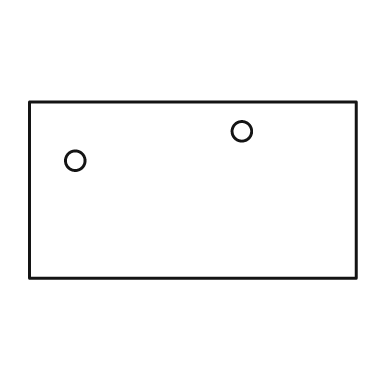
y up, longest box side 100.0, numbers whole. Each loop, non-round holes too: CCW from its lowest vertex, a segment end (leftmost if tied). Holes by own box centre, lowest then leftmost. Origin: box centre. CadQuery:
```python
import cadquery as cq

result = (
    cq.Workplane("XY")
    .moveTo(-50.0, -27.0)
    .lineTo(50.0, -27.0)
    .lineTo(50.0, 27.0)
    .lineTo(-50.0, 27.0)
    .close()
    .moveTo(-36.0, 9.0)
    .circle(3.0)
    .moveTo(15.0, 18.0)
    .circle(3.0)
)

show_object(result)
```